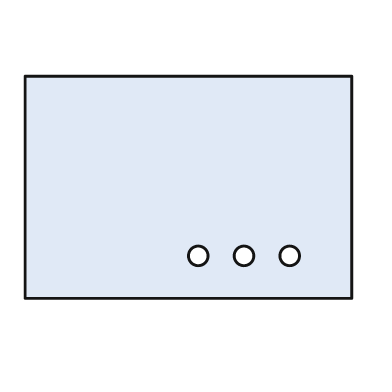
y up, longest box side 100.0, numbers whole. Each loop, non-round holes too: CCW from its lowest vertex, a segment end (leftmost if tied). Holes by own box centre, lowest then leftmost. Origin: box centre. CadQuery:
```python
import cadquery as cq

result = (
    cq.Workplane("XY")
    .moveTo(-50.0, -34.0)
    .lineTo(50.0, -34.0)
    .lineTo(50.0, 34.0)
    .lineTo(-50.0, 34.0)
    .close()
    .moveTo(3.0, -21.0)
    .circle(3.0)
    .moveTo(17.0, -21.0)
    .circle(3.0)
    .moveTo(31.0, -21.0)
    .circle(3.0)
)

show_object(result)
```